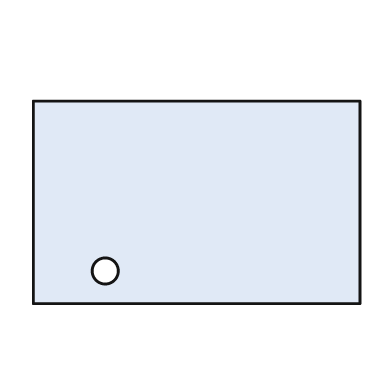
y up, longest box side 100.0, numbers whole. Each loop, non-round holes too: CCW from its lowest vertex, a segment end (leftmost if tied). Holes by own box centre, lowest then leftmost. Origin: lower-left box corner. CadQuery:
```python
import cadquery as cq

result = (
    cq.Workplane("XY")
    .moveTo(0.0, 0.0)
    .lineTo(100.0, 0.0)
    .lineTo(100.0, 62.0)
    .lineTo(0.0, 62.0)
    .close()
    .moveTo(22.0, 10.0)
    .circle(4.0)
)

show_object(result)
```